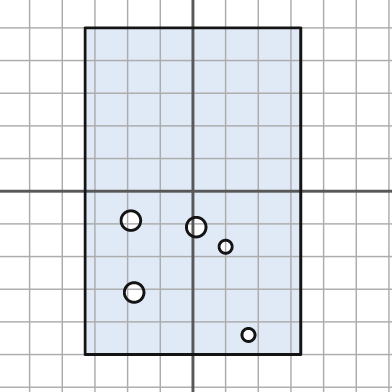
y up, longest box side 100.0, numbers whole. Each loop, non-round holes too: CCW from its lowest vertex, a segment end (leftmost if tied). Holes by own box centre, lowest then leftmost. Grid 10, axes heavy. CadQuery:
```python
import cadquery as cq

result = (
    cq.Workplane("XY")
    .moveTo(-33.0, -50.0)
    .lineTo(33.0, -50.0)
    .lineTo(33.0, 50.0)
    .lineTo(-33.0, 50.0)
    .close()
    .moveTo(17.0, -44.0)
    .circle(2.0)
    .moveTo(-18.0, -31.0)
    .circle(3.0)
    .moveTo(10.0, -17.0)
    .circle(2.0)
    .moveTo(1.0, -11.0)
    .circle(3.0)
    .moveTo(-19.0, -9.0)
    .circle(3.0)
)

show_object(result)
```